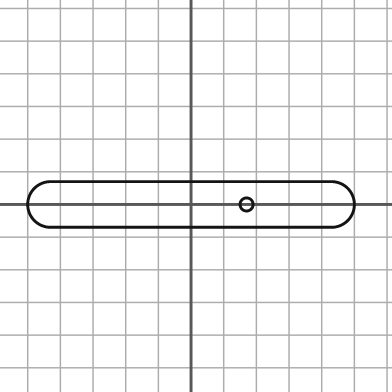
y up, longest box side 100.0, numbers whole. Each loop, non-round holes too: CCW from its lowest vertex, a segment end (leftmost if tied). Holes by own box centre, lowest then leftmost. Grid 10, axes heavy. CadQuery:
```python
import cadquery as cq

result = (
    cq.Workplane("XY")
    .moveTo(-43.0, -7.0)
    .lineTo(43.0, -7.0)
    .threePointArc((50.0, 0.0), (43.0, 7.0))
    .lineTo(-43.0, 7.0)
    .threePointArc((-50.0, 0.0), (-43.0, -7.0))
    .close()
    .moveTo(17.0, 0.0)
    .circle(2.0)
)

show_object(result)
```